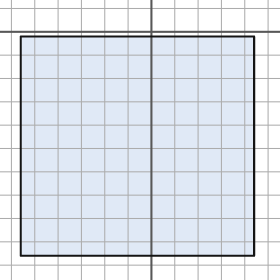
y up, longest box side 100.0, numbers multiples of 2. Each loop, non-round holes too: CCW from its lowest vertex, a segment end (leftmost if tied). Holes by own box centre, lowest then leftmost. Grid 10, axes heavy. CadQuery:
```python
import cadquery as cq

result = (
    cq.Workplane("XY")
    .moveTo(-56.0, -96.0)
    .lineTo(44.0, -96.0)
    .lineTo(44.0, -2.0)
    .lineTo(-56.0, -2.0)
    .close()
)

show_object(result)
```